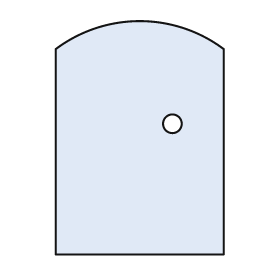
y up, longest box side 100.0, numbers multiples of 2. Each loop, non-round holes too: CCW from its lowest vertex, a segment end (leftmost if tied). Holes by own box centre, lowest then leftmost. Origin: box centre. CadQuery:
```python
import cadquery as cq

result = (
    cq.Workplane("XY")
    .moveTo(-36.0, -50.0)
    .lineTo(36.0, -50.0)
    .lineTo(36.0, 38.0)
    .threePointArc((0.0, 50.0), (-36.0, 38.0))
    .close()
    .moveTo(14.0, 6.0)
    .circle(4.0)
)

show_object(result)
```